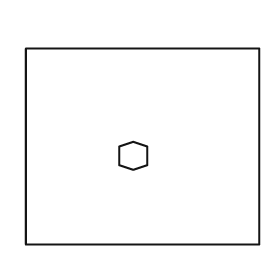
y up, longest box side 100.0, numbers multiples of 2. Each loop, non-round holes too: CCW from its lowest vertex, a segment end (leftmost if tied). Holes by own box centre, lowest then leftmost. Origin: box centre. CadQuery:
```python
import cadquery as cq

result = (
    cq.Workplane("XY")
    .moveTo(-50.0, -42.0)
    .lineTo(50.0, -42.0)
    .lineTo(50.0, 42.0)
    .lineTo(-50.0, 42.0)
    .close()
    .moveTo(-4.0, -10.0)
    .lineTo(2.0, -8.0)
    .lineTo(2.0, 0.0)
    .lineTo(-4.0, 2.0)
    .lineTo(-10.0, 0.0)
    .lineTo(-10.0, -8.0)
    .close()
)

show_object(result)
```